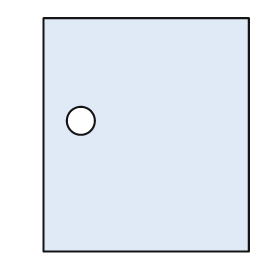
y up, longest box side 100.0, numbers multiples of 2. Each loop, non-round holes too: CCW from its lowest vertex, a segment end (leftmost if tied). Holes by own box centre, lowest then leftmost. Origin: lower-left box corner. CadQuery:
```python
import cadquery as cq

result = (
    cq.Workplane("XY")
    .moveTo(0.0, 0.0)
    .lineTo(88.0, 0.0)
    .lineTo(88.0, 100.0)
    .lineTo(0.0, 100.0)
    .close()
    .moveTo(16.0, 56.0)
    .circle(6.0)
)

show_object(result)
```